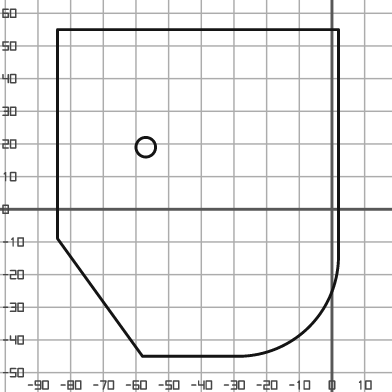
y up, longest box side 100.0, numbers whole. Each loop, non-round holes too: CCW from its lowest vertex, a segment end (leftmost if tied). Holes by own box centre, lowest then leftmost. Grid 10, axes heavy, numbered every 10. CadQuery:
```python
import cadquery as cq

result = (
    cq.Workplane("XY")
    .moveTo(-58.0, -45.0)
    .lineTo(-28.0, -45.0)
    .threePointArc((-7.0, -36.0), (2.0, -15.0))
    .lineTo(2.0, 55.0)
    .lineTo(-84.0, 55.0)
    .lineTo(-84.0, -9.0)
    .close()
    .moveTo(-57.0, 19.0)
    .circle(3.0)
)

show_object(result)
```